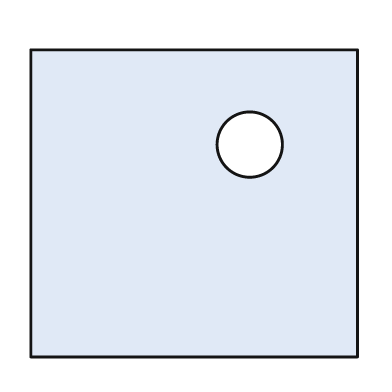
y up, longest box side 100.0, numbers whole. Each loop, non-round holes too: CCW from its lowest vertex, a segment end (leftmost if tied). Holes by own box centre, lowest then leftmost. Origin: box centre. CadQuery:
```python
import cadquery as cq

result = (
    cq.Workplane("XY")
    .moveTo(-50.0, -47.0)
    .lineTo(50.0, -47.0)
    .lineTo(50.0, 47.0)
    .lineTo(-50.0, 47.0)
    .close()
    .moveTo(17.0, 18.0)
    .circle(10.0)
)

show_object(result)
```